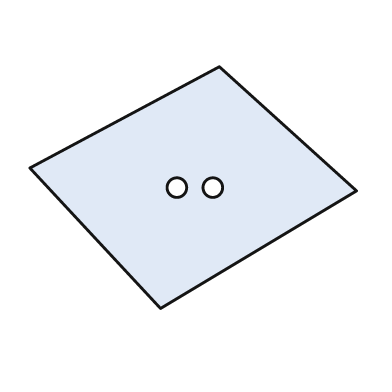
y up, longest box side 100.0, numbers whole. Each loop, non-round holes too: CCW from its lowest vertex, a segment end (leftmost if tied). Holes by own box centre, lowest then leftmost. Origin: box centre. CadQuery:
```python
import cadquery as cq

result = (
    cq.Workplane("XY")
    .moveTo(-10.0, -37.0)
    .lineTo(50.0, -1.0)
    .lineTo(8.0, 37.0)
    .lineTo(-50.0, 6.0)
    .close()
    .moveTo(-5.0, 0.0)
    .circle(3.0)
    .moveTo(6.0, 0.0)
    .circle(3.0)
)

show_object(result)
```